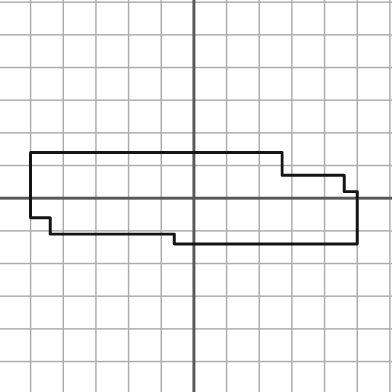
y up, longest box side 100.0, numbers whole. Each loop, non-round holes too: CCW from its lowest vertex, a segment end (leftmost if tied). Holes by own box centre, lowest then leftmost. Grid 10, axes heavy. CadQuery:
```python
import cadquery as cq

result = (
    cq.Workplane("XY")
    .moveTo(-6.0, -14.0)
    .lineTo(50.0, -14.0)
    .lineTo(50.0, 2.0)
    .lineTo(46.0, 2.0)
    .lineTo(46.0, 7.0)
    .lineTo(27.0, 7.0)
    .lineTo(27.0, 14.0)
    .lineTo(-50.0, 14.0)
    .lineTo(-50.0, -6.0)
    .lineTo(-44.0, -6.0)
    .lineTo(-44.0, -11.0)
    .lineTo(-6.0, -11.0)
    .close()
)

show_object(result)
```